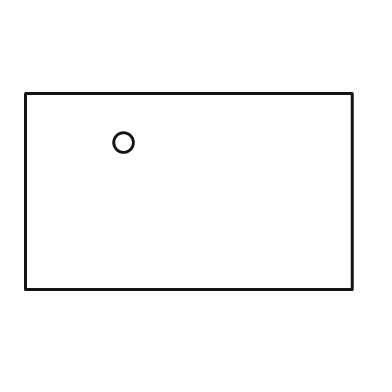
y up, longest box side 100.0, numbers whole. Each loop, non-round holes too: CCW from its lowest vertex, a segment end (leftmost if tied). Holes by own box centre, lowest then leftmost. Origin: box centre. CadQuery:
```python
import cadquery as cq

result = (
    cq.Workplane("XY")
    .moveTo(-50.0, -30.0)
    .lineTo(50.0, -30.0)
    .lineTo(50.0, 30.0)
    .lineTo(-50.0, 30.0)
    .close()
    .moveTo(-20.0, 15.0)
    .circle(3.0)
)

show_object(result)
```